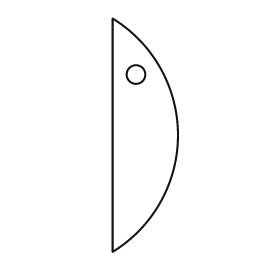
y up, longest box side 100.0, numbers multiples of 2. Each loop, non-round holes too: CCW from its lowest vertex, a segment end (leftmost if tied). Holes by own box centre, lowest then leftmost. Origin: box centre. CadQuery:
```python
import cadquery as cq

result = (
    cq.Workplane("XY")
    .moveTo(-14.0, -50.0)
    .threePointArc((14.0, 0.0), (-14.0, 50.0))
    .close()
    .moveTo(-4.0, 26.0)
    .circle(4.0)
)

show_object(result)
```